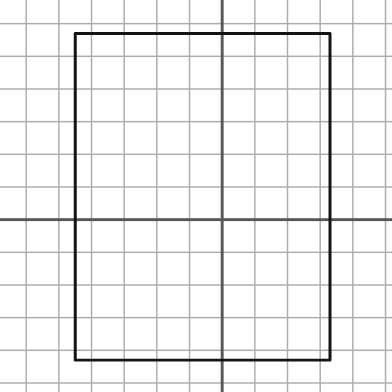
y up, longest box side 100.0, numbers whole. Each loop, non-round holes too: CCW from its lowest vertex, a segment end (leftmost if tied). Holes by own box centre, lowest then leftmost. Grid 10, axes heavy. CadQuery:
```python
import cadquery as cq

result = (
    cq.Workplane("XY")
    .moveTo(-45.0, -43.0)
    .lineTo(33.0, -43.0)
    .lineTo(33.0, 57.0)
    .lineTo(-45.0, 57.0)
    .close()
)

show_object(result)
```